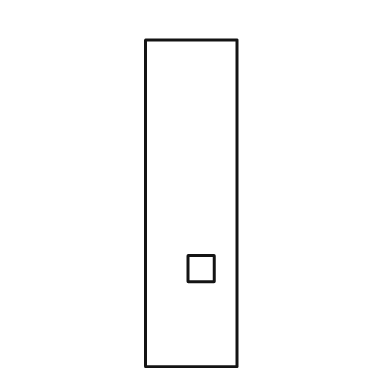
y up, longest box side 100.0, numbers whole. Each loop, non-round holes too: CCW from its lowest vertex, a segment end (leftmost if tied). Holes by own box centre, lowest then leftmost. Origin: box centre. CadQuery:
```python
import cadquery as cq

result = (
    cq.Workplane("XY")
    .moveTo(-14.0, -50.0)
    .lineTo(14.0, -50.0)
    .lineTo(14.0, 50.0)
    .lineTo(-14.0, 50.0)
    .close()
    .moveTo(-1.0, -24.0)
    .lineTo(7.0, -24.0)
    .lineTo(7.0, -16.0)
    .lineTo(-1.0, -16.0)
    .close()
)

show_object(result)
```